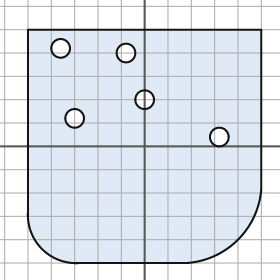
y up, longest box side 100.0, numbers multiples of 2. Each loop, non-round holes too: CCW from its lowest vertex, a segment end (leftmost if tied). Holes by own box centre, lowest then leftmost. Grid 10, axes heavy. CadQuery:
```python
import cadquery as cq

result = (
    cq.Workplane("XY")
    .moveTo(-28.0, -50.0)
    .lineTo(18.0, -50.0)
    .threePointArc((40.0, -40.0), (50.0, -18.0))
    .lineTo(50.0, 50.0)
    .lineTo(-50.0, 50.0)
    .lineTo(-50.0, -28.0)
    .threePointArc((-44.0, -44.0), (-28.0, -50.0))
    .close()
    .moveTo(32.0, 4.0)
    .circle(4.0)
    .moveTo(-30.0, 12.0)
    .circle(4.0)
    .moveTo(0.0, 20.0)
    .circle(4.0)
    .moveTo(-8.0, 40.0)
    .circle(4.0)
    .moveTo(-36.0, 42.0)
    .circle(4.0)
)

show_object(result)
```